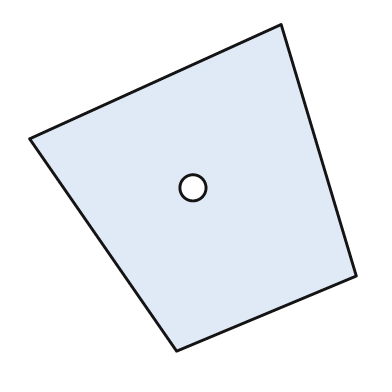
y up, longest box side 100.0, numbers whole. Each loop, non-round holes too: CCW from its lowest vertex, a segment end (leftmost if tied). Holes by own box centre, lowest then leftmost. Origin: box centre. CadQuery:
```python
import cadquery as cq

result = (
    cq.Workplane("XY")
    .moveTo(-5.0, -50.0)
    .lineTo(50.0, -27.0)
    .lineTo(27.0, 50.0)
    .lineTo(-50.0, 15.0)
    .close()
    .moveTo(0.0, 0.0)
    .circle(4.0)
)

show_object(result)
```